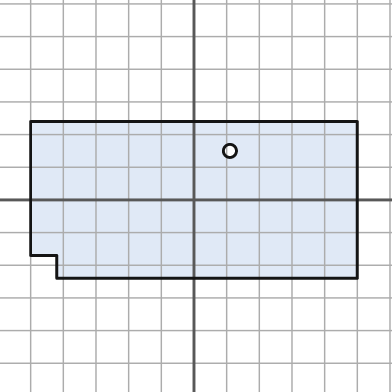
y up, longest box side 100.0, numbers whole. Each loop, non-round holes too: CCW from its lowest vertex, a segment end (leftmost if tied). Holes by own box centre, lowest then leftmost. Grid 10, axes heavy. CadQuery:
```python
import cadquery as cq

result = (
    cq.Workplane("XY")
    .moveTo(-42.0, -24.0)
    .lineTo(50.0, -24.0)
    .lineTo(50.0, 24.0)
    .lineTo(-50.0, 24.0)
    .lineTo(-50.0, -17.0)
    .lineTo(-42.0, -17.0)
    .close()
    .moveTo(11.0, 15.0)
    .circle(2.0)
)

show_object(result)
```